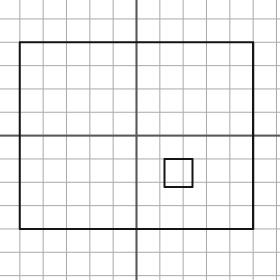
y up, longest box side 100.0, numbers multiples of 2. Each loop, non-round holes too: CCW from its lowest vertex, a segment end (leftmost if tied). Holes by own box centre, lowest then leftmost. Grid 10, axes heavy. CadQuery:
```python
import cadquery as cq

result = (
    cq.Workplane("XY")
    .moveTo(-50.0, -40.0)
    .lineTo(50.0, -40.0)
    .lineTo(50.0, 40.0)
    .lineTo(-50.0, 40.0)
    .close()
    .moveTo(12.0, -22.0)
    .lineTo(24.0, -22.0)
    .lineTo(24.0, -10.0)
    .lineTo(12.0, -10.0)
    .close()
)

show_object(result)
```